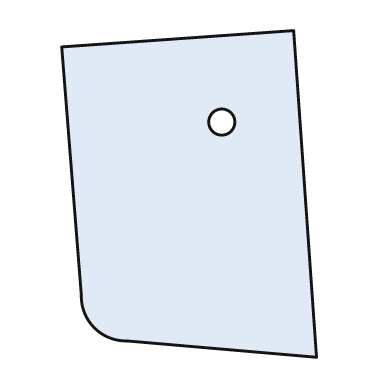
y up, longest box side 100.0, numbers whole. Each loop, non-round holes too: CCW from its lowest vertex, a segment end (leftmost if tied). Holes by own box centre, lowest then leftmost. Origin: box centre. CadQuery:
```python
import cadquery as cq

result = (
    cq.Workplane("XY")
    .moveTo(39.0, -50.0)
    .lineTo(32.0, 50.0)
    .lineTo(-39.0, 45.0)
    .lineTo(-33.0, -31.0)
    .threePointArc((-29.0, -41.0), (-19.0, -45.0))
    .close()
    .moveTo(10.0, 22.0)
    .circle(4.0)
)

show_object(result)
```